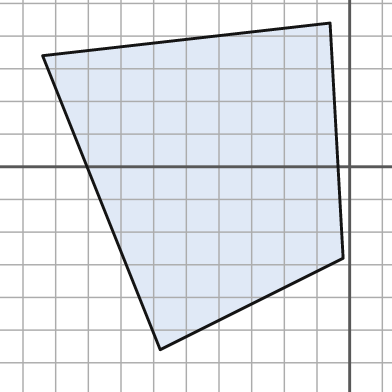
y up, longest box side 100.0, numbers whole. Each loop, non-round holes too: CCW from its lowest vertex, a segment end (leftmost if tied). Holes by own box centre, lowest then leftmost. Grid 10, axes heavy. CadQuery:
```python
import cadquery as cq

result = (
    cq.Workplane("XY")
    .moveTo(-58.0, -56.0)
    .lineTo(-2.0, -28.0)
    .lineTo(-6.0, 44.0)
    .lineTo(-94.0, 34.0)
    .close()
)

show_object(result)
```